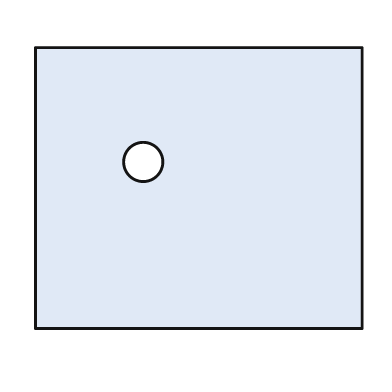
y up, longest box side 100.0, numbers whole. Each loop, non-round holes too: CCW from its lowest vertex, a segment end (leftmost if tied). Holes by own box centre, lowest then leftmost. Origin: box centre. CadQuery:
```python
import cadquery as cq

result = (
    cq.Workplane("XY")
    .moveTo(-50.0, -43.0)
    .lineTo(50.0, -43.0)
    .lineTo(50.0, 43.0)
    .lineTo(-50.0, 43.0)
    .close()
    .moveTo(-17.0, 8.0)
    .circle(6.0)
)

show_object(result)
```